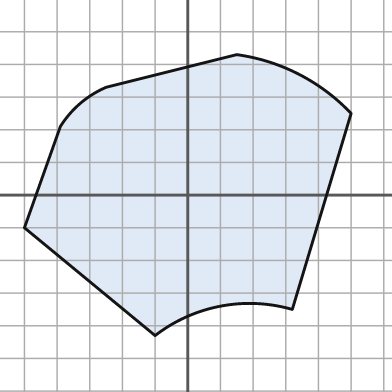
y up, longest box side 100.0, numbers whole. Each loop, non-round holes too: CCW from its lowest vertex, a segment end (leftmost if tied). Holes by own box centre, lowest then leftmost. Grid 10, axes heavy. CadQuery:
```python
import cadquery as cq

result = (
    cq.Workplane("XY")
    .moveTo(-10.0, -43.0)
    .threePointArc((10.0, -34.0), (32.0, -35.0))
    .lineTo(50.0, 25.0)
    .threePointArc((34.0, 37.0), (15.0, 43.0))
    .lineTo(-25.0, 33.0)
    .threePointArc((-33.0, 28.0), (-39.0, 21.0))
    .lineTo(-50.0, -10.0)
    .close()
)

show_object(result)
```